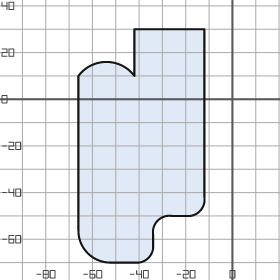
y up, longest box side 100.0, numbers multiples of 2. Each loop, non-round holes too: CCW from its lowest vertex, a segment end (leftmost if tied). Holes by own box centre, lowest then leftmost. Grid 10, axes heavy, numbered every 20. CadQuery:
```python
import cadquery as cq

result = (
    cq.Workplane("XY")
    .moveTo(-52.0, -70.0)
    .lineTo(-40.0, -70.0)
    .threePointArc((-36.0, -68.0), (-34.0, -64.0))
    .lineTo(-34.0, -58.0)
    .threePointArc((-32.0, -52.0), (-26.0, -50.0))
    .lineTo(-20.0, -50.0)
    .threePointArc((-14.0, -48.0), (-12.0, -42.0))
    .lineTo(-12.0, 30.0)
    .lineTo(-42.0, 30.0)
    .lineTo(-42.0, 10.0)
    .threePointArc((-54.0, 16.0), (-66.0, 10.0))
    .lineTo(-66.0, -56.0)
    .threePointArc((-62.0, -66.0), (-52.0, -70.0))
    .close()
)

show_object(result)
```